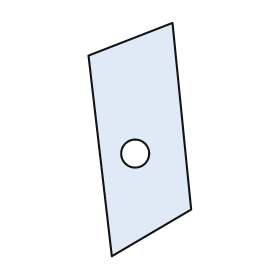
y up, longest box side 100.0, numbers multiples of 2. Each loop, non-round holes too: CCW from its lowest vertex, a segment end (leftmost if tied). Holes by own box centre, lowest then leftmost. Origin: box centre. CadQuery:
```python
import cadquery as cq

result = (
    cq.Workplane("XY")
    .moveTo(-12.0, -50.0)
    .lineTo(22.0, -30.0)
    .lineTo(14.0, 50.0)
    .lineTo(-22.0, 36.0)
    .close()
    .moveTo(-2.0, -6.0)
    .circle(6.0)
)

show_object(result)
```